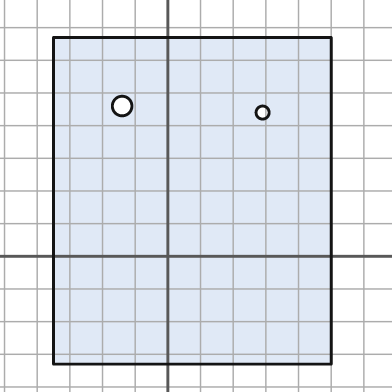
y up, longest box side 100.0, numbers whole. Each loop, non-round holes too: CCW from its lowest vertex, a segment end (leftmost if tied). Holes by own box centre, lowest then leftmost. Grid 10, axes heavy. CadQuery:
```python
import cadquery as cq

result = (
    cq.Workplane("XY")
    .moveTo(-35.0, -33.0)
    .lineTo(50.0, -33.0)
    .lineTo(50.0, 67.0)
    .lineTo(-35.0, 67.0)
    .close()
    .moveTo(29.0, 44.0)
    .circle(2.0)
    .moveTo(-14.0, 46.0)
    .circle(3.0)
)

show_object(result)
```